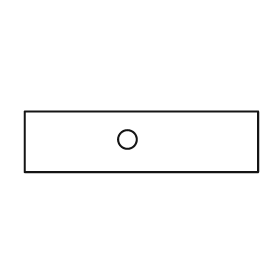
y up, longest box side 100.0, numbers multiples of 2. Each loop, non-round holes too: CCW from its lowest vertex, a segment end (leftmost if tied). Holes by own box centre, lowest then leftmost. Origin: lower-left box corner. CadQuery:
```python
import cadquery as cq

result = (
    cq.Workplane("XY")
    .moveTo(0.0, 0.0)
    .lineTo(100.0, 0.0)
    .lineTo(100.0, 26.0)
    .lineTo(0.0, 26.0)
    .close()
    .moveTo(44.0, 14.0)
    .circle(4.0)
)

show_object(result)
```